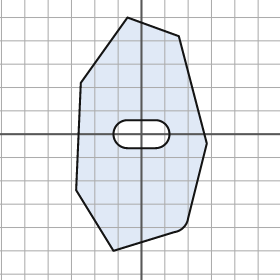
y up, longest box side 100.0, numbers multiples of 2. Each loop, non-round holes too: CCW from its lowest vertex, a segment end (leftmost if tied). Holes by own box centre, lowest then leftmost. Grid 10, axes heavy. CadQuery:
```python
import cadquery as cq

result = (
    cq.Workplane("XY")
    .moveTo(-12.0, -50.0)
    .lineTo(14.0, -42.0)
    .threePointArc((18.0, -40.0), (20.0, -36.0))
    .lineTo(28.0, -4.0)
    .lineTo(16.0, 42.0)
    .lineTo(-6.0, 50.0)
    .lineTo(-26.0, 22.0)
    .lineTo(-28.0, -24.0)
    .close()
    .moveTo(-6.0, -6.0)
    .lineTo(6.0, -6.0)
    .threePointArc((12.0, 0.0), (6.0, 6.0))
    .lineTo(-6.0, 6.0)
    .threePointArc((-12.0, 0.0), (-6.0, -6.0))
    .close()
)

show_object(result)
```